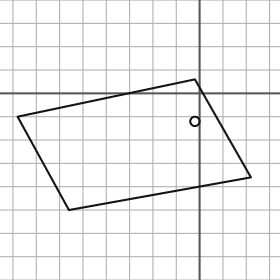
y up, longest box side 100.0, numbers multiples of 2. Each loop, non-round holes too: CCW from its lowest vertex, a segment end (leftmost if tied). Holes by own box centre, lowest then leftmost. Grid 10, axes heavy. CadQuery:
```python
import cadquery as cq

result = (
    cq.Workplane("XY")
    .moveTo(-56.0, -50.0)
    .lineTo(22.0, -36.0)
    .lineTo(-2.0, 6.0)
    .lineTo(-78.0, -10.0)
    .close()
    .moveTo(-2.0, -12.0)
    .circle(2.0)
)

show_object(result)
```